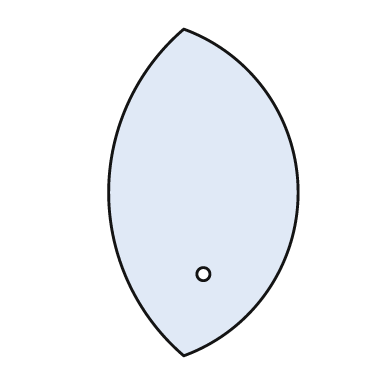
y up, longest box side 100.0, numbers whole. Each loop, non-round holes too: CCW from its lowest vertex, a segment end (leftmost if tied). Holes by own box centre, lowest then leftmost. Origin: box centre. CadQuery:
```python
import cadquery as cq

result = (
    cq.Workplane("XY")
    .moveTo(-6.0, -50.0)
    .threePointArc((29.0, 0.0), (-6.0, 50.0))
    .threePointArc((-29.0, 0.0), (-6.0, -50.0))
    .close()
    .moveTo(0.0, -25.0)
    .circle(2.0)
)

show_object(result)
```